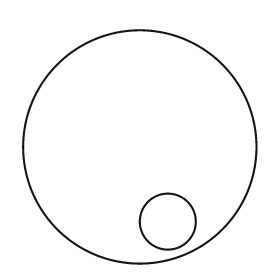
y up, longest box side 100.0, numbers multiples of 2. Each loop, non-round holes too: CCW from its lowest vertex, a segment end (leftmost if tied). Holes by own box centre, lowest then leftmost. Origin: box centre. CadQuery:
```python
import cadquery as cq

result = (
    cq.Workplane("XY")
    .moveTo(0.0, 0.0)
    .circle(50.0)
    .moveTo(12.0, -32.0)
    .circle(12.0)
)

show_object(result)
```